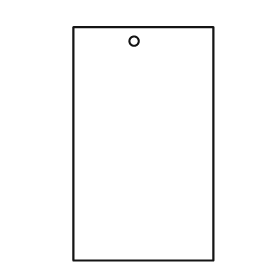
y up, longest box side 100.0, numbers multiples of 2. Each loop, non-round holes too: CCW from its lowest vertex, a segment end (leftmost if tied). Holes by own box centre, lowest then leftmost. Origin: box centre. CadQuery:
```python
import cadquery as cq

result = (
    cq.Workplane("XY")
    .moveTo(-30.0, -50.0)
    .lineTo(30.0, -50.0)
    .lineTo(30.0, 50.0)
    .lineTo(-30.0, 50.0)
    .close()
    .moveTo(-4.0, 44.0)
    .circle(2.0)
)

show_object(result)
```